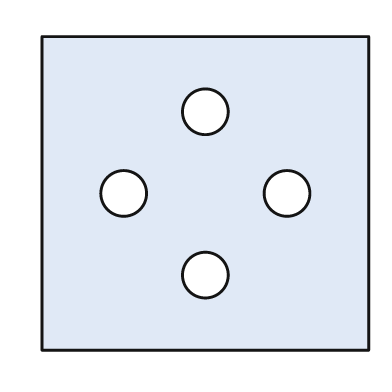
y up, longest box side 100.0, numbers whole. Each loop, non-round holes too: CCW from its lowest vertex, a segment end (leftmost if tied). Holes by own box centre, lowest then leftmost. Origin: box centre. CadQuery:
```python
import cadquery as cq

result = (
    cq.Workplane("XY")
    .moveTo(-50.0, -48.0)
    .lineTo(50.0, -48.0)
    .lineTo(50.0, 48.0)
    .lineTo(-50.0, 48.0)
    .close()
    .moveTo(0.0, -25.0)
    .circle(7.0)
    .moveTo(-25.0, 0.0)
    .circle(7.0)
    .moveTo(25.0, 0.0)
    .circle(7.0)
    .moveTo(0.0, 25.0)
    .circle(7.0)
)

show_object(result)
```